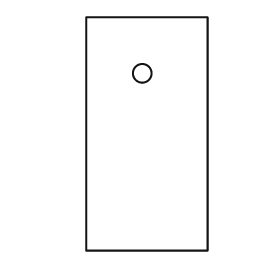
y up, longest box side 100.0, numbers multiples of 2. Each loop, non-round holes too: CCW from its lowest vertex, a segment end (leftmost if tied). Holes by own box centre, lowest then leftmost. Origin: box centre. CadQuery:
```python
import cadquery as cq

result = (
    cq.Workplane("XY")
    .moveTo(-26.0, -50.0)
    .lineTo(26.0, -50.0)
    .lineTo(26.0, 50.0)
    .lineTo(-26.0, 50.0)
    .close()
    .moveTo(-2.0, 26.0)
    .circle(4.0)
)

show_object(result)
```